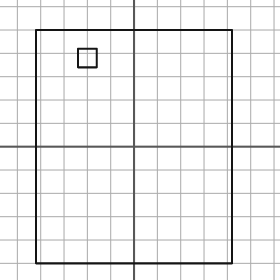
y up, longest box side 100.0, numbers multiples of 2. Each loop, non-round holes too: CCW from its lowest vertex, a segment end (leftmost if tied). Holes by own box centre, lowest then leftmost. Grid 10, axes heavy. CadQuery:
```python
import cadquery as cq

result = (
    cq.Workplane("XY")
    .moveTo(-42.0, -50.0)
    .lineTo(42.0, -50.0)
    .lineTo(42.0, 50.0)
    .lineTo(-42.0, 50.0)
    .close()
    .moveTo(-24.0, 34.0)
    .lineTo(-16.0, 34.0)
    .lineTo(-16.0, 42.0)
    .lineTo(-24.0, 42.0)
    .close()
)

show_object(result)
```